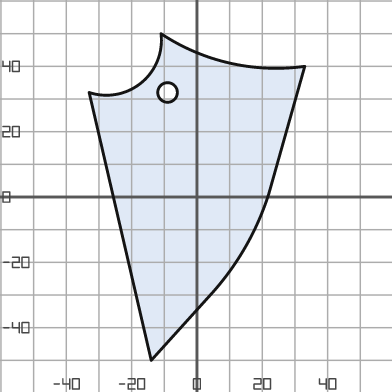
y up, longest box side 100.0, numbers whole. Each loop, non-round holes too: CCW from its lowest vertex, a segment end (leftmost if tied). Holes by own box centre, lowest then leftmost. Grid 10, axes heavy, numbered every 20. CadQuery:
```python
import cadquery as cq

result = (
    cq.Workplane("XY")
    .moveTo(-14.0, -50.0)
    .lineTo(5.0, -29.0)
    .threePointArc((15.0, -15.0), (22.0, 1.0))
    .lineTo(33.0, 40.0)
    .threePointArc((10.0, 41.0), (-11.0, 50.0))
    .threePointArc((-17.0, 35.0), (-33.0, 32.0))
    .close()
    .moveTo(-9.0, 32.0)
    .circle(3.0)
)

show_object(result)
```